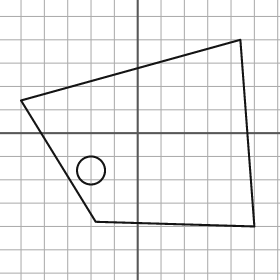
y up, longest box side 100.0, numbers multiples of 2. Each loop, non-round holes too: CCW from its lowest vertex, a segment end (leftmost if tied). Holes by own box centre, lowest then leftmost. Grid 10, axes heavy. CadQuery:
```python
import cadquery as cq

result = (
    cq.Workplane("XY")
    .moveTo(50.0, -40.0)
    .lineTo(44.0, 40.0)
    .lineTo(-50.0, 14.0)
    .lineTo(-18.0, -38.0)
    .close()
    .moveTo(-20.0, -16.0)
    .circle(6.0)
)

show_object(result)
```